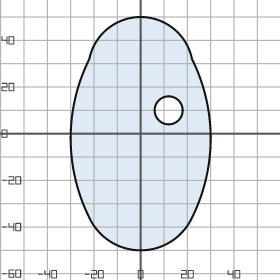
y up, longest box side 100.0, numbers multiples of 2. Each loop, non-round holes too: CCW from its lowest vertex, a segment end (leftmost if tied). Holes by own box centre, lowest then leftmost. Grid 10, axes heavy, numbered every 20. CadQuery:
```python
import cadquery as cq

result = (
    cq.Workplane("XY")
    .moveTo(-22.0, -36.0)
    .threePointArc((0.0, -50.0), (22.0, -36.0))
    .threePointArc((30.0, -2.0), (22.0, 32.0))
    .threePointArc((0.0, 50.0), (-22.0, 32.0))
    .threePointArc((-30.0, -2.0), (-22.0, -36.0))
    .close()
    .moveTo(12.0, 10.0)
    .circle(6.0)
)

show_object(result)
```